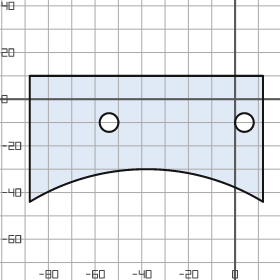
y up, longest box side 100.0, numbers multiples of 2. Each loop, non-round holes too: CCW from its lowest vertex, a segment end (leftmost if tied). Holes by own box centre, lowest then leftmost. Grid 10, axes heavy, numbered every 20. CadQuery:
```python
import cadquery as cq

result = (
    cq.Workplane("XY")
    .moveTo(-88.0, -44.0)
    .threePointArc((-38.0, -30.0), (12.0, -44.0))
    .lineTo(12.0, 10.0)
    .lineTo(-88.0, 10.0)
    .close()
    .moveTo(-54.0, -10.0)
    .circle(4.0)
    .moveTo(4.0, -10.0)
    .circle(4.0)
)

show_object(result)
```